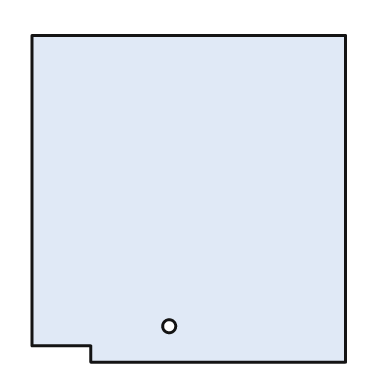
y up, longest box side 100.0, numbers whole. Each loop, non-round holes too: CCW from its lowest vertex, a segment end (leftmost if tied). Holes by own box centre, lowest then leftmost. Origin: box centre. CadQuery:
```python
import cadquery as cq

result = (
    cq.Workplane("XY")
    .moveTo(-30.0, -50.0)
    .lineTo(48.0, -50.0)
    .lineTo(48.0, 50.0)
    .lineTo(-48.0, 50.0)
    .lineTo(-48.0, -45.0)
    .lineTo(-30.0, -45.0)
    .close()
    .moveTo(-6.0, -39.0)
    .circle(2.0)
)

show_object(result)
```